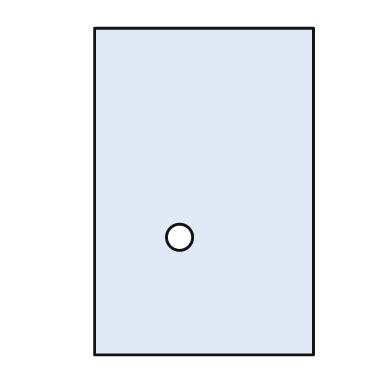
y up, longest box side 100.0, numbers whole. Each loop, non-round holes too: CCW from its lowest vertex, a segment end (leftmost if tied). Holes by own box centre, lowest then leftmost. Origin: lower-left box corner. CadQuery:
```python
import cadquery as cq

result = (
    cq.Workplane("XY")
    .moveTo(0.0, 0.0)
    .lineTo(67.0, 0.0)
    .lineTo(67.0, 100.0)
    .lineTo(0.0, 100.0)
    .close()
    .moveTo(26.0, 36.0)
    .circle(4.0)
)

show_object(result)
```